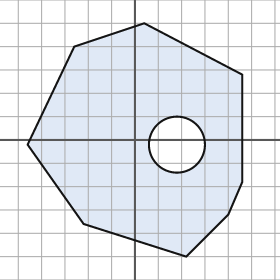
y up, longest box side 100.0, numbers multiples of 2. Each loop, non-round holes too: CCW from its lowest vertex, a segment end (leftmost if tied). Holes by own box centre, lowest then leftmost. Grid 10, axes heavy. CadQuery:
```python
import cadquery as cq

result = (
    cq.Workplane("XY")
    .moveTo(22.0, -50.0)
    .lineTo(40.0, -32.0)
    .lineTo(46.0, -18.0)
    .lineTo(46.0, 28.0)
    .lineTo(4.0, 50.0)
    .lineTo(-26.0, 40.0)
    .lineTo(-46.0, -2.0)
    .lineTo(-22.0, -36.0)
    .close()
    .moveTo(18.0, -2.0)
    .circle(12.0)
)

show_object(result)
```